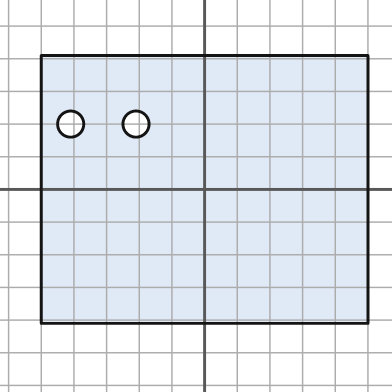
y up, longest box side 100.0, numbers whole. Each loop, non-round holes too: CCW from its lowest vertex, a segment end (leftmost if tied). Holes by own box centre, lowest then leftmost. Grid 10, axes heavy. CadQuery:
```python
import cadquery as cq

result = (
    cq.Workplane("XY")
    .moveTo(-50.0, -41.0)
    .lineTo(50.0, -41.0)
    .lineTo(50.0, 41.0)
    .lineTo(-50.0, 41.0)
    .close()
    .moveTo(-41.0, 20.0)
    .circle(4.0)
    .moveTo(-21.0, 20.0)
    .circle(4.0)
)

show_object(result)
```